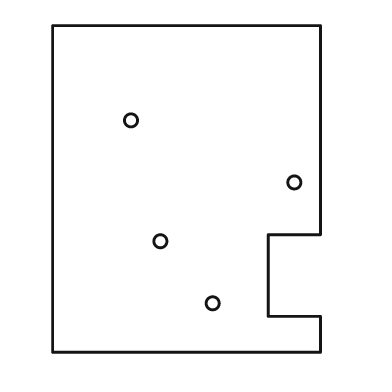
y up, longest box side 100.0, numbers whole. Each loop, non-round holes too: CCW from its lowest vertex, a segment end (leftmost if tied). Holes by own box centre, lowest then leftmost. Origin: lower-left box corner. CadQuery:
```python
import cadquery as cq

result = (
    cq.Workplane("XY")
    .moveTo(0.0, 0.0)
    .lineTo(82.0, 0.0)
    .lineTo(82.0, 11.0)
    .lineTo(66.0, 11.0)
    .lineTo(66.0, 36.0)
    .lineTo(82.0, 36.0)
    .lineTo(82.0, 100.0)
    .lineTo(0.0, 100.0)
    .close()
    .moveTo(49.0, 15.0)
    .circle(2.0)
    .moveTo(33.0, 34.0)
    .circle(2.0)
    .moveTo(74.0, 52.0)
    .circle(2.0)
    .moveTo(24.0, 71.0)
    .circle(2.0)
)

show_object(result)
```